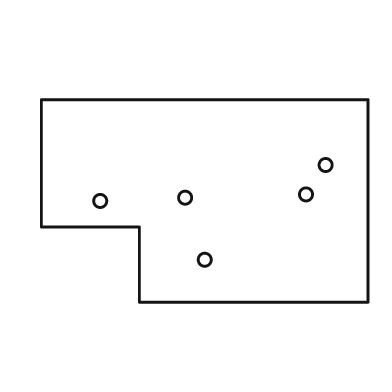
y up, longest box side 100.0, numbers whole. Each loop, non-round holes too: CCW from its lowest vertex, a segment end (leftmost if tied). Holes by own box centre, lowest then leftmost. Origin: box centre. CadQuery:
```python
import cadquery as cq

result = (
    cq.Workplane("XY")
    .moveTo(-20.0, -31.0)
    .lineTo(50.0, -31.0)
    .lineTo(50.0, 31.0)
    .lineTo(-50.0, 31.0)
    .lineTo(-50.0, -8.0)
    .lineTo(-20.0, -8.0)
    .close()
    .moveTo(0.0, -18.0)
    .circle(2.0)
    .moveTo(-32.0, 0.0)
    .circle(2.0)
    .moveTo(-6.0, 1.0)
    .circle(2.0)
    .moveTo(31.0, 2.0)
    .circle(2.0)
    .moveTo(37.0, 11.0)
    .circle(2.0)
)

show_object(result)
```